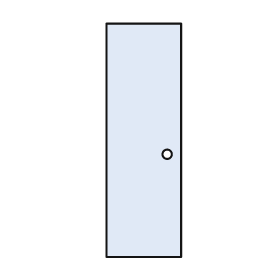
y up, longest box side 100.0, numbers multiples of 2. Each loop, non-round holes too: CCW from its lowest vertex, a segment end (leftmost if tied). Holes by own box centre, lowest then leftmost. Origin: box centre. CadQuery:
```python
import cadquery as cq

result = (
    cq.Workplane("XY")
    .moveTo(-16.0, -50.0)
    .lineTo(16.0, -50.0)
    .lineTo(16.0, 50.0)
    .lineTo(-16.0, 50.0)
    .close()
    .moveTo(10.0, -6.0)
    .circle(2.0)
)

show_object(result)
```